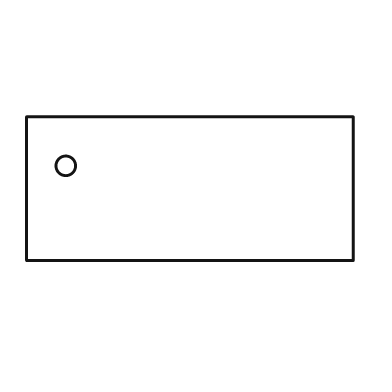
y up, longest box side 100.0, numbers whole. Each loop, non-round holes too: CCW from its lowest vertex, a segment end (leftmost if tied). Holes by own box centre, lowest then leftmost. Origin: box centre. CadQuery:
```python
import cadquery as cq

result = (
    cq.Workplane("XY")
    .moveTo(-50.0, -22.0)
    .lineTo(50.0, -22.0)
    .lineTo(50.0, 22.0)
    .lineTo(-50.0, 22.0)
    .close()
    .moveTo(-38.0, 7.0)
    .circle(3.0)
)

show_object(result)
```